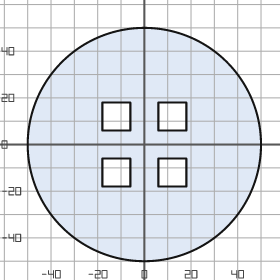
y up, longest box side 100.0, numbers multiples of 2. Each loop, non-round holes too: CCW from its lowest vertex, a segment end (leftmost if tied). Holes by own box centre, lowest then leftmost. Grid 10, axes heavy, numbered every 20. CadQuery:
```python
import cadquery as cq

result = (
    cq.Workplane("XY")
    .moveTo(0.0, 0.0)
    .circle(50.0)
    .moveTo(-18.0, -18.0)
    .lineTo(-6.0, -18.0)
    .lineTo(-6.0, -6.0)
    .lineTo(-18.0, -6.0)
    .close()
    .moveTo(6.0, -18.0)
    .lineTo(18.0, -18.0)
    .lineTo(18.0, -6.0)
    .lineTo(6.0, -6.0)
    .close()
    .moveTo(-18.0, 6.0)
    .lineTo(-6.0, 6.0)
    .lineTo(-6.0, 18.0)
    .lineTo(-18.0, 18.0)
    .close()
    .moveTo(6.0, 6.0)
    .lineTo(18.0, 6.0)
    .lineTo(18.0, 18.0)
    .lineTo(6.0, 18.0)
    .close()
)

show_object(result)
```